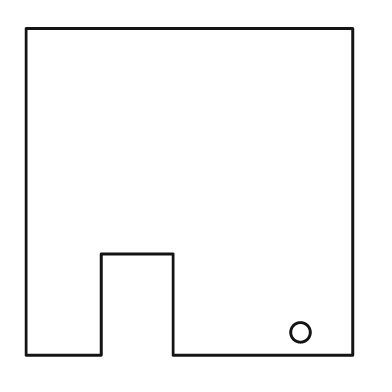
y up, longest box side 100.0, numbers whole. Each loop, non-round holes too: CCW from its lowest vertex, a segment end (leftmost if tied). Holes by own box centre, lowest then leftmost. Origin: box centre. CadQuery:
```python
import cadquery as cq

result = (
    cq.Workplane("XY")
    .moveTo(-50.0, -50.0)
    .lineTo(-27.0, -50.0)
    .lineTo(-27.0, -19.0)
    .lineTo(-5.0, -19.0)
    .lineTo(-5.0, -50.0)
    .lineTo(50.0, -50.0)
    .lineTo(50.0, 50.0)
    .lineTo(-50.0, 50.0)
    .close()
    .moveTo(34.0, -43.0)
    .circle(3.0)
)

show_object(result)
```